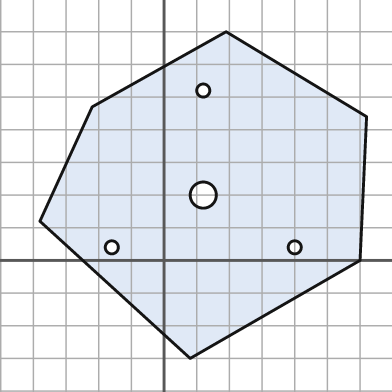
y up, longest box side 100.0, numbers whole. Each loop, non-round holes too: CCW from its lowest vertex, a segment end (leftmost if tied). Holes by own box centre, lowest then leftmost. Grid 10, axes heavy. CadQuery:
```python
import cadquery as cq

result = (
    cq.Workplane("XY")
    .moveTo(8.0, -30.0)
    .lineTo(60.0, 0.0)
    .lineTo(62.0, 44.0)
    .lineTo(19.0, 70.0)
    .lineTo(-22.0, 47.0)
    .lineTo(-38.0, 12.0)
    .close()
    .moveTo(-16.0, 4.0)
    .circle(2.0)
    .moveTo(40.0, 4.0)
    .circle(2.0)
    .moveTo(12.0, 20.0)
    .circle(4.0)
    .moveTo(12.0, 52.0)
    .circle(2.0)
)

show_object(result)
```